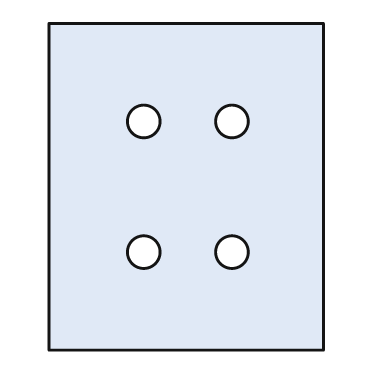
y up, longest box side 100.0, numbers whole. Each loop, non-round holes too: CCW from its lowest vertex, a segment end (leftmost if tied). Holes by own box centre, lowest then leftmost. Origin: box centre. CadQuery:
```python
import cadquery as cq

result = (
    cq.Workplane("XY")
    .moveTo(-42.0, -50.0)
    .lineTo(42.0, -50.0)
    .lineTo(42.0, 50.0)
    .lineTo(-42.0, 50.0)
    .close()
    .moveTo(-13.0, -20.0)
    .circle(5.0)
    .moveTo(14.0, -20.0)
    .circle(5.0)
    .moveTo(-13.0, 20.0)
    .circle(5.0)
    .moveTo(14.0, 20.0)
    .circle(5.0)
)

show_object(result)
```